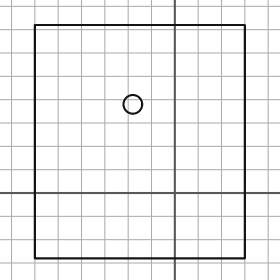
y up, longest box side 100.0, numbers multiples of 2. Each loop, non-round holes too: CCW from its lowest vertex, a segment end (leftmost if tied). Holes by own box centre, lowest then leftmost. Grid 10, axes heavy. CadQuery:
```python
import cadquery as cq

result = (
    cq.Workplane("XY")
    .moveTo(-60.0, -28.0)
    .lineTo(30.0, -28.0)
    .lineTo(30.0, 72.0)
    .lineTo(-60.0, 72.0)
    .close()
    .moveTo(-18.0, 38.0)
    .circle(4.0)
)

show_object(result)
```